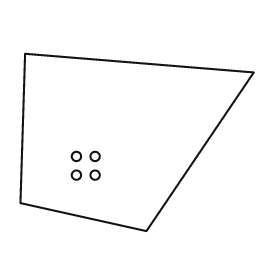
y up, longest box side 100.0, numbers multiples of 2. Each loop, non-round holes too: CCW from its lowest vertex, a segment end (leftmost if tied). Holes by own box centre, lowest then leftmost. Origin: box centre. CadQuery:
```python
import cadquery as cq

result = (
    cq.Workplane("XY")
    .moveTo(4.0, -38.0)
    .lineTo(50.0, 30.0)
    .lineTo(-48.0, 38.0)
    .lineTo(-50.0, -26.0)
    .close()
    .moveTo(-26.0, -14.0)
    .circle(2.0)
    .moveTo(-18.0, -14.0)
    .circle(2.0)
    .moveTo(-26.0, -6.0)
    .circle(2.0)
    .moveTo(-18.0, -6.0)
    .circle(2.0)
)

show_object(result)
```